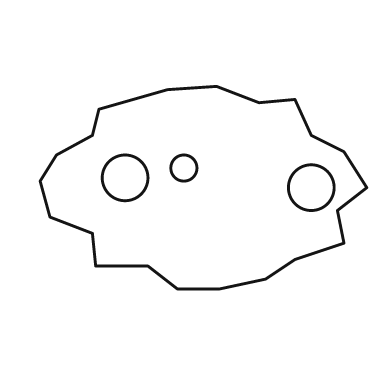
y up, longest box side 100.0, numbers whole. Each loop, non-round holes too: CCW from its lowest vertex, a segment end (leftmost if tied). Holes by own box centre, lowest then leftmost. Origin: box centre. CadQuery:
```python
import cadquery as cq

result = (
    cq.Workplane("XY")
    .moveTo(-8.0, -31.0)
    .lineTo(5.0, -31.0)
    .lineTo(19.0, -28.0)
    .lineTo(28.0, -22.0)
    .lineTo(43.0, -17.0)
    .lineTo(41.0, -7.0)
    .lineTo(50.0, 0.0)
    .lineTo(43.0, 11.0)
    .lineTo(33.0, 16.0)
    .lineTo(28.0, 27.0)
    .lineTo(17.0, 26.0)
    .lineTo(4.0, 31.0)
    .lineTo(-11.0, 30.0)
    .lineTo(-32.0, 24.0)
    .lineTo(-34.0, 16.0)
    .lineTo(-45.0, 10.0)
    .lineTo(-50.0, 2.0)
    .lineTo(-47.0, -9.0)
    .lineTo(-34.0, -14.0)
    .lineTo(-33.0, -24.0)
    .lineTo(-17.0, -24.0)
    .close()
    .moveTo(33.0, 0.0)
    .circle(7.0)
    .moveTo(-24.0, 3.0)
    .circle(7.0)
    .moveTo(-6.0, 6.0)
    .circle(4.0)
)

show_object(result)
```